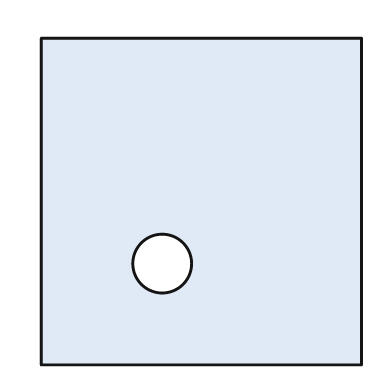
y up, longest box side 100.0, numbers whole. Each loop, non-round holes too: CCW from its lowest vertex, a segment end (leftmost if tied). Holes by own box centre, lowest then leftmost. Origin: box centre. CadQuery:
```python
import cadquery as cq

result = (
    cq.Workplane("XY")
    .moveTo(-49.0, -50.0)
    .lineTo(49.0, -50.0)
    .lineTo(49.0, 50.0)
    .lineTo(-49.0, 50.0)
    .close()
    .moveTo(-12.0, -19.0)
    .circle(9.0)
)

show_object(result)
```